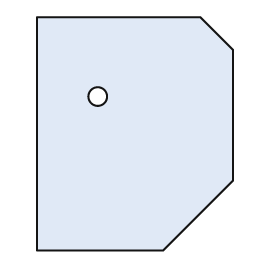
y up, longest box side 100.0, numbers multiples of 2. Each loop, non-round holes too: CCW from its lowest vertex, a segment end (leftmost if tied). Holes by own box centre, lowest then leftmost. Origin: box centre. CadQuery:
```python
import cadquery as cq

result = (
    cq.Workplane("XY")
    .moveTo(-42.0, -50.0)
    .lineTo(12.0, -50.0)
    .lineTo(42.0, -20.0)
    .lineTo(42.0, 36.0)
    .lineTo(28.0, 50.0)
    .lineTo(-42.0, 50.0)
    .close()
    .moveTo(-16.0, 16.0)
    .circle(4.0)
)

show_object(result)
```